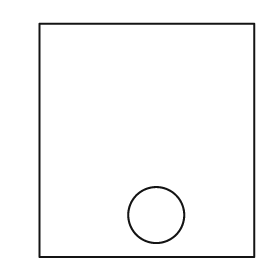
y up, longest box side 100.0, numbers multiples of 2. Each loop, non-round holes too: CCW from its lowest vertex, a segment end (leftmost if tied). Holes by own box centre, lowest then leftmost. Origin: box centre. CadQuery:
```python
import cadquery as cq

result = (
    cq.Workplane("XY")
    .moveTo(-46.0, -50.0)
    .lineTo(46.0, -50.0)
    .lineTo(46.0, 50.0)
    .lineTo(-46.0, 50.0)
    .close()
    .moveTo(4.0, -32.0)
    .circle(12.0)
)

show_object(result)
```